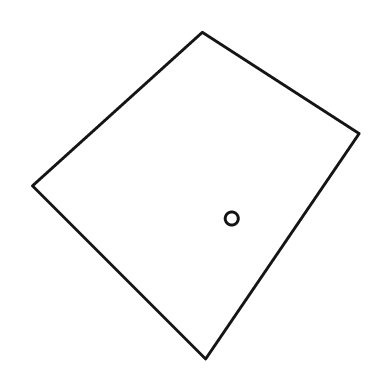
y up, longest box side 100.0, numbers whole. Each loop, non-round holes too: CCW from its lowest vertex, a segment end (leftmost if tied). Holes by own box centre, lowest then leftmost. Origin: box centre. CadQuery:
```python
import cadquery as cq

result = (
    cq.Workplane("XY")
    .moveTo(3.0, -50.0)
    .lineTo(50.0, 19.0)
    .lineTo(2.0, 50.0)
    .lineTo(-50.0, 3.0)
    .close()
    .moveTo(11.0, -7.0)
    .circle(2.0)
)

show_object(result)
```